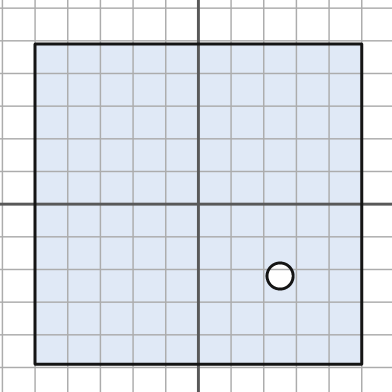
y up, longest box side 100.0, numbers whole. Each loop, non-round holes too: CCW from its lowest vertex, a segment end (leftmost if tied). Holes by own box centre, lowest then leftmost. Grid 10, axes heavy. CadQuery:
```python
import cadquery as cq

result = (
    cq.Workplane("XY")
    .moveTo(-50.0, -49.0)
    .lineTo(50.0, -49.0)
    .lineTo(50.0, 49.0)
    .lineTo(-50.0, 49.0)
    .close()
    .moveTo(25.0, -22.0)
    .circle(4.0)
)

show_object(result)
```